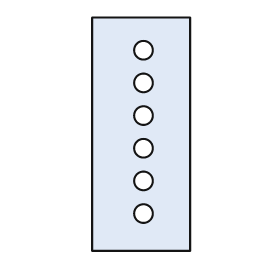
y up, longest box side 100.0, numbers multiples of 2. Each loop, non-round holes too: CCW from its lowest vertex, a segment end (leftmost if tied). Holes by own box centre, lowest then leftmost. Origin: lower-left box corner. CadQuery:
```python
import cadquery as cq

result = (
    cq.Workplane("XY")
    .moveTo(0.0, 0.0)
    .lineTo(42.0, 0.0)
    .lineTo(42.0, 100.0)
    .lineTo(0.0, 100.0)
    .close()
    .moveTo(22.0, 16.0)
    .circle(4.0)
    .moveTo(22.0, 30.0)
    .circle(4.0)
    .moveTo(22.0, 44.0)
    .circle(4.0)
    .moveTo(22.0, 58.0)
    .circle(4.0)
    .moveTo(22.0, 72.0)
    .circle(4.0)
    .moveTo(22.0, 86.0)
    .circle(4.0)
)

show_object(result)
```